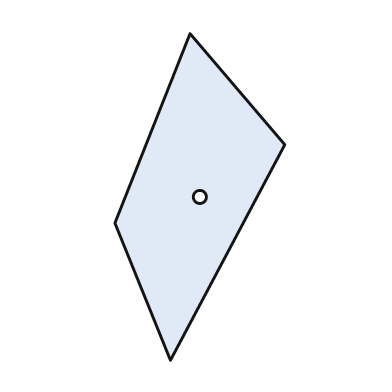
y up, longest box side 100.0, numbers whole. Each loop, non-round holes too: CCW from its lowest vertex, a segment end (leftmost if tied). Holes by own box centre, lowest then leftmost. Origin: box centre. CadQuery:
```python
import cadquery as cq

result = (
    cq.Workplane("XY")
    .moveTo(-9.0, -50.0)
    .lineTo(26.0, 16.0)
    .lineTo(-3.0, 50.0)
    .lineTo(-26.0, -8.0)
    .close()
    .moveTo(0.0, 0.0)
    .circle(2.0)
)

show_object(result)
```